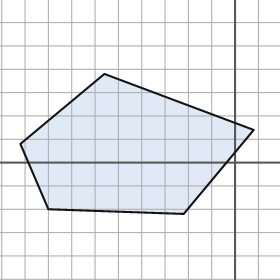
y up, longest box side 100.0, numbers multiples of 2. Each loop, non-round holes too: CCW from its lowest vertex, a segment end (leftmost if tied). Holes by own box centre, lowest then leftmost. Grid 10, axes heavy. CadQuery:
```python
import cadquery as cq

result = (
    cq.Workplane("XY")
    .moveTo(-22.0, -22.0)
    .lineTo(8.0, 14.0)
    .lineTo(-56.0, 38.0)
    .lineTo(-92.0, 8.0)
    .lineTo(-80.0, -20.0)
    .close()
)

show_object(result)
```